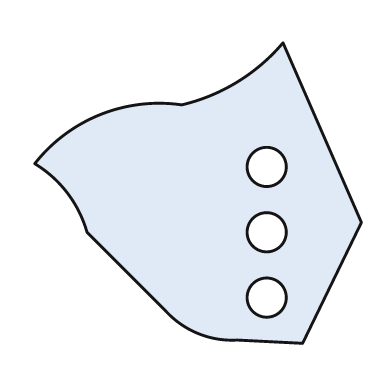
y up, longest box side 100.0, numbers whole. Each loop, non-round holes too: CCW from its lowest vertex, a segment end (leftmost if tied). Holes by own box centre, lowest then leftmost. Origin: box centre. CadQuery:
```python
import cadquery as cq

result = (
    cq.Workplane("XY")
    .moveTo(32.0, -46.0)
    .lineTo(50.0, -9.0)
    .lineTo(26.0, 46.0)
    .threePointArc((12.0, 34.0), (-5.0, 27.0))
    .threePointArc((-30.0, 24.0), (-50.0, 9.0))
    .threePointArc((-40.0, 0.0), (-34.0, -12.0))
    .lineTo(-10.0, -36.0)
    .threePointArc((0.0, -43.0), (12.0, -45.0))
    .close()
    .moveTo(21.0, -32.0)
    .circle(6.0)
    .moveTo(21.0, -12.0)
    .circle(6.0)
    .moveTo(21.0, 8.0)
    .circle(6.0)
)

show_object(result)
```